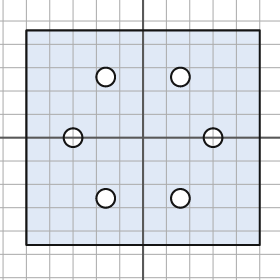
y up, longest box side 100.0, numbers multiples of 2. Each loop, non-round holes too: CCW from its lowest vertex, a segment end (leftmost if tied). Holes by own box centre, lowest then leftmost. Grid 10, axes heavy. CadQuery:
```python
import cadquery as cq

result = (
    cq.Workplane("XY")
    .moveTo(-50.0, -46.0)
    .lineTo(50.0, -46.0)
    .lineTo(50.0, 46.0)
    .lineTo(-50.0, 46.0)
    .close()
    .moveTo(-16.0, -26.0)
    .circle(4.0)
    .moveTo(16.0, -26.0)
    .circle(4.0)
    .moveTo(-30.0, 0.0)
    .circle(4.0)
    .moveTo(30.0, 0.0)
    .circle(4.0)
    .moveTo(-16.0, 26.0)
    .circle(4.0)
    .moveTo(16.0, 26.0)
    .circle(4.0)
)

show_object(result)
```